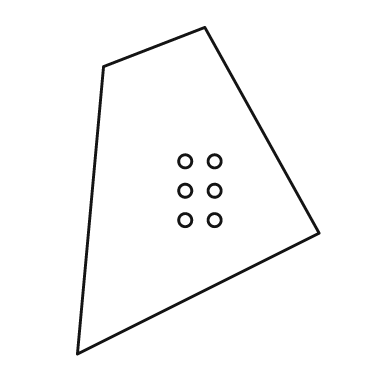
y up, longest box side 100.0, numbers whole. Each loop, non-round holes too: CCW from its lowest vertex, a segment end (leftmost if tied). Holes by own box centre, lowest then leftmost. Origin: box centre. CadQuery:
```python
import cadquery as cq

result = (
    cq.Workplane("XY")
    .moveTo(-37.0, -50.0)
    .lineTo(37.0, -13.0)
    .lineTo(2.0, 50.0)
    .lineTo(-29.0, 38.0)
    .close()
    .moveTo(-4.0, -9.0)
    .circle(2.0)
    .moveTo(5.0, -9.0)
    .circle(2.0)
    .moveTo(-4.0, 0.0)
    .circle(2.0)
    .moveTo(5.0, 0.0)
    .circle(2.0)
    .moveTo(-4.0, 9.0)
    .circle(2.0)
    .moveTo(5.0, 9.0)
    .circle(2.0)
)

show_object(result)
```